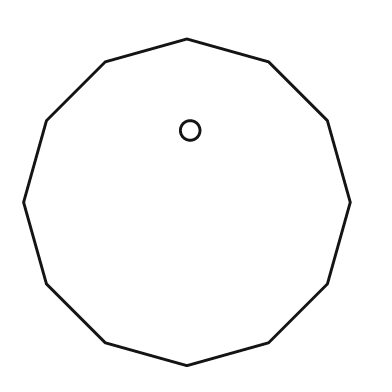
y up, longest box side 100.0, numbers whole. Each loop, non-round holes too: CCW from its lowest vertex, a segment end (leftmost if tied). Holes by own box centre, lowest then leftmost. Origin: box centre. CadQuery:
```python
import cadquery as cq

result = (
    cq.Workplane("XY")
    .moveTo(0.0, -50.0)
    .lineTo(25.0, -43.0)
    .lineTo(43.0, -25.0)
    .lineTo(50.0, 0.0)
    .lineTo(43.0, 25.0)
    .lineTo(25.0, 43.0)
    .lineTo(0.0, 50.0)
    .lineTo(-25.0, 43.0)
    .lineTo(-43.0, 25.0)
    .lineTo(-50.0, 0.0)
    .lineTo(-43.0, -25.0)
    .lineTo(-25.0, -43.0)
    .close()
    .moveTo(1.0, 22.0)
    .circle(3.0)
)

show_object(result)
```